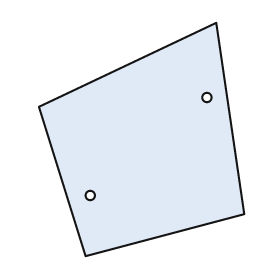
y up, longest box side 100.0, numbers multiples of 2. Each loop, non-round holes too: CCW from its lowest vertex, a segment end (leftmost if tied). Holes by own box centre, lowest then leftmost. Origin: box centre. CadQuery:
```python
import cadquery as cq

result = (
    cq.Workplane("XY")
    .moveTo(-24.0, -50.0)
    .lineTo(44.0, -32.0)
    .lineTo(32.0, 50.0)
    .lineTo(-44.0, 14.0)
    .close()
    .moveTo(-22.0, -24.0)
    .circle(2.0)
    .moveTo(28.0, 18.0)
    .circle(2.0)
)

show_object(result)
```